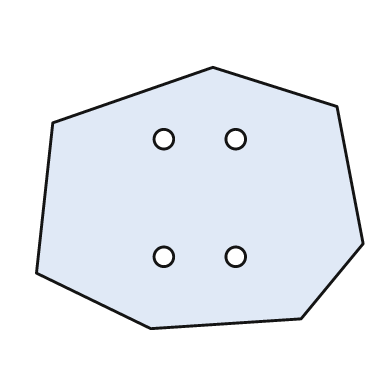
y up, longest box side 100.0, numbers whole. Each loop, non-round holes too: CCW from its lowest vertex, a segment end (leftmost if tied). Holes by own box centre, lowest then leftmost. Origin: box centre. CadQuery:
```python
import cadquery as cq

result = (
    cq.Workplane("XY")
    .moveTo(-15.0, -40.0)
    .lineTo(31.0, -37.0)
    .lineTo(50.0, -14.0)
    .lineTo(42.0, 28.0)
    .lineTo(4.0, 40.0)
    .lineTo(-45.0, 23.0)
    .lineTo(-50.0, -23.0)
    .close()
    .moveTo(-11.0, -18.0)
    .circle(3.0)
    .moveTo(11.0, -18.0)
    .circle(3.0)
    .moveTo(-11.0, 18.0)
    .circle(3.0)
    .moveTo(11.0, 18.0)
    .circle(3.0)
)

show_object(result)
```